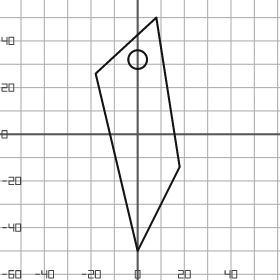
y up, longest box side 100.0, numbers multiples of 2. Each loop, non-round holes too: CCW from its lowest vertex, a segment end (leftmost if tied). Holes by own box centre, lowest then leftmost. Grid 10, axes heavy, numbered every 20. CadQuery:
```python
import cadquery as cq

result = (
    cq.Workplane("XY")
    .moveTo(0.0, -50.0)
    .lineTo(18.0, -14.0)
    .lineTo(8.0, 50.0)
    .lineTo(-18.0, 26.0)
    .close()
    .moveTo(0.0, 32.0)
    .circle(4.0)
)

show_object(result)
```